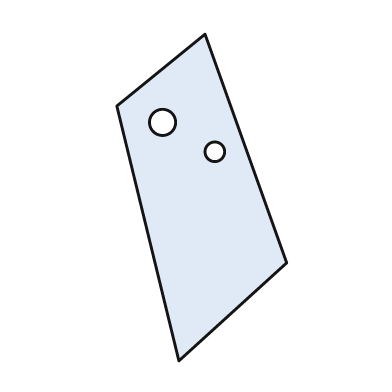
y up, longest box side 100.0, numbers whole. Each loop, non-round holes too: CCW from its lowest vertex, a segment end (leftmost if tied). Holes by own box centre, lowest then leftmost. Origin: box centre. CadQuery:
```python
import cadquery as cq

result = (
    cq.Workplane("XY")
    .moveTo(-7.0, -50.0)
    .lineTo(26.0, -20.0)
    .lineTo(1.0, 50.0)
    .lineTo(-26.0, 28.0)
    .close()
    .moveTo(4.0, 14.0)
    .circle(3.0)
    .moveTo(-12.0, 23.0)
    .circle(4.0)
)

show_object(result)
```